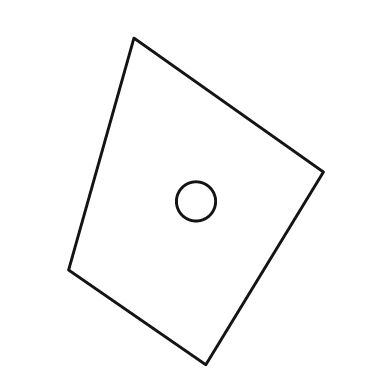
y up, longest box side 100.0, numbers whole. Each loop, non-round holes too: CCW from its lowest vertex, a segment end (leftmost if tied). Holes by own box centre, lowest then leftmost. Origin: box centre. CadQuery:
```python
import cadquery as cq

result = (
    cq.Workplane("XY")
    .moveTo(3.0, -50.0)
    .lineTo(39.0, 9.0)
    .lineTo(-19.0, 50.0)
    .lineTo(-39.0, -21.0)
    .close()
    .moveTo(0.0, 0.0)
    .circle(6.0)
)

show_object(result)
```